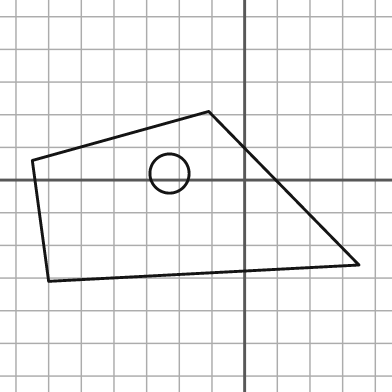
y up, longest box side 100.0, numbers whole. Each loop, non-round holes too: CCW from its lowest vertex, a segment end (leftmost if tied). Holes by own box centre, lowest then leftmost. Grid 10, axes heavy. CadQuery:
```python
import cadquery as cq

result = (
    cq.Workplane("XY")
    .moveTo(-60.0, -31.0)
    .lineTo(35.0, -26.0)
    .lineTo(-11.0, 21.0)
    .lineTo(-65.0, 6.0)
    .close()
    .moveTo(-23.0, 2.0)
    .circle(6.0)
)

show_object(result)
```